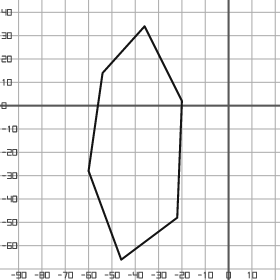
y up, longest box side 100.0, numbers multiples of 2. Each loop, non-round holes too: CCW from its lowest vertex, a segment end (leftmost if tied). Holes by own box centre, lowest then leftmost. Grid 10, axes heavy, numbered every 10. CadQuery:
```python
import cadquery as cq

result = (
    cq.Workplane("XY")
    .moveTo(-46.0, -66.0)
    .lineTo(-22.0, -48.0)
    .lineTo(-20.0, 2.0)
    .lineTo(-36.0, 34.0)
    .lineTo(-54.0, 14.0)
    .lineTo(-60.0, -28.0)
    .close()
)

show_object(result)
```